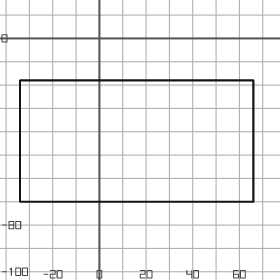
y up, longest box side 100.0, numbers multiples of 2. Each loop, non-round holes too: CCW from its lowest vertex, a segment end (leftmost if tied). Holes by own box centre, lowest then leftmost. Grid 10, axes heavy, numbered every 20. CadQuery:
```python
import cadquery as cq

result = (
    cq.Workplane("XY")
    .moveTo(-34.0, -70.0)
    .lineTo(66.0, -70.0)
    .lineTo(66.0, -18.0)
    .lineTo(-34.0, -18.0)
    .close()
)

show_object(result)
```